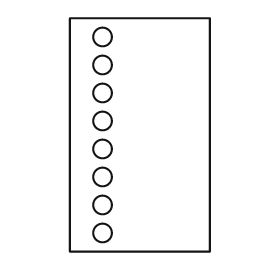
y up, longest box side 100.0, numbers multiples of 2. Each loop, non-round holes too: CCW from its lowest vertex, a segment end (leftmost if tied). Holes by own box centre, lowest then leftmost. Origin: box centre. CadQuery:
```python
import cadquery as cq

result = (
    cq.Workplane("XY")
    .moveTo(-30.0, -50.0)
    .lineTo(30.0, -50.0)
    .lineTo(30.0, 50.0)
    .lineTo(-30.0, 50.0)
    .close()
    .moveTo(-16.0, -42.0)
    .circle(4.0)
    .moveTo(-16.0, -30.0)
    .circle(4.0)
    .moveTo(-16.0, -18.0)
    .circle(4.0)
    .moveTo(-16.0, -6.0)
    .circle(4.0)
    .moveTo(-16.0, 6.0)
    .circle(4.0)
    .moveTo(-16.0, 18.0)
    .circle(4.0)
    .moveTo(-16.0, 30.0)
    .circle(4.0)
    .moveTo(-16.0, 42.0)
    .circle(4.0)
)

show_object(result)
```